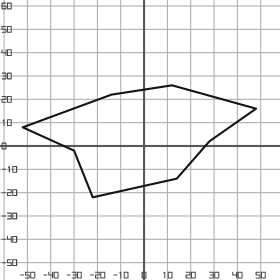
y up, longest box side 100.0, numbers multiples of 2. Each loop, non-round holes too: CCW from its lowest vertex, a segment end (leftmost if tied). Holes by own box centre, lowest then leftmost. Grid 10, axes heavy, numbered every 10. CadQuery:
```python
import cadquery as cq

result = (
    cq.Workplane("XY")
    .moveTo(-22.0, -22.0)
    .lineTo(14.0, -14.0)
    .lineTo(28.0, 2.0)
    .lineTo(48.0, 16.0)
    .lineTo(12.0, 26.0)
    .lineTo(-14.0, 22.0)
    .lineTo(-52.0, 8.0)
    .lineTo(-30.0, -2.0)
    .close()
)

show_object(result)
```